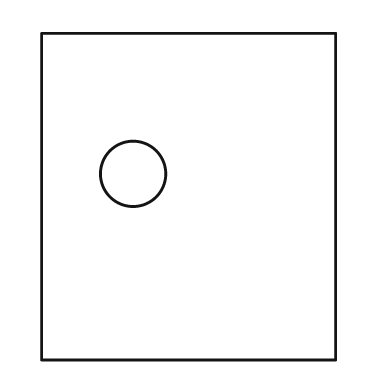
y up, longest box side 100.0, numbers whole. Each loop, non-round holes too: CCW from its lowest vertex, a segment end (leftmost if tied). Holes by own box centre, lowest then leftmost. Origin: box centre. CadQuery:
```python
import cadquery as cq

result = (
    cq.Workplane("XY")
    .moveTo(-45.0, -50.0)
    .lineTo(45.0, -50.0)
    .lineTo(45.0, 50.0)
    .lineTo(-45.0, 50.0)
    .close()
    .moveTo(-17.0, 7.0)
    .circle(10.0)
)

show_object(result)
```